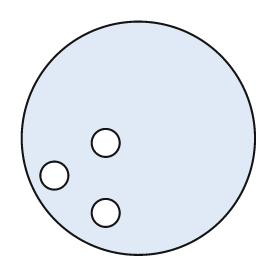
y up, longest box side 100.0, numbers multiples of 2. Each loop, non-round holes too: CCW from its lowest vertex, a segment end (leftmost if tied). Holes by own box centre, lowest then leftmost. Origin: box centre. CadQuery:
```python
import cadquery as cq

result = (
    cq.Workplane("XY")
    .moveTo(0.0, 0.0)
    .circle(50.0)
    .moveTo(-14.0, -32.0)
    .circle(6.0)
    .moveTo(-36.0, -16.0)
    .circle(6.0)
    .moveTo(-14.0, -2.0)
    .circle(6.0)
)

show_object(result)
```